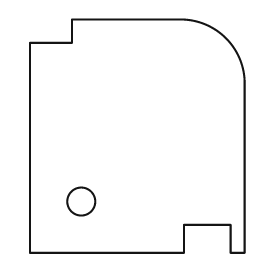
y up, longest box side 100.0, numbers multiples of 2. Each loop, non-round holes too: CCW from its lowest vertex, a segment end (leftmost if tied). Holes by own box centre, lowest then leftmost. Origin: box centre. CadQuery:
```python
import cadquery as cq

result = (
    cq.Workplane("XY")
    .moveTo(-46.0, -50.0)
    .lineTo(20.0, -50.0)
    .lineTo(20.0, -38.0)
    .lineTo(40.0, -38.0)
    .lineTo(40.0, -50.0)
    .lineTo(46.0, -50.0)
    .lineTo(46.0, 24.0)
    .threePointArc((38.0, 42.0), (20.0, 50.0))
    .lineTo(-28.0, 50.0)
    .lineTo(-28.0, 40.0)
    .lineTo(-46.0, 40.0)
    .close()
    .moveTo(-24.0, -28.0)
    .circle(6.0)
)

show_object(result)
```